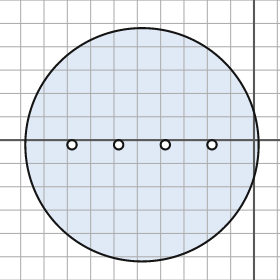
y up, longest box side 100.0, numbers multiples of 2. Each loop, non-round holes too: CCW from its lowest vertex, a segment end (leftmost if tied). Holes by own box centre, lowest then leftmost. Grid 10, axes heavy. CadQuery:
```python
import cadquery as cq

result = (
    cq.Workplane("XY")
    .moveTo(-48.0, -2.0)
    .circle(50.0)
    .moveTo(-78.0, -2.0)
    .circle(2.0)
    .moveTo(-58.0, -2.0)
    .circle(2.0)
    .moveTo(-38.0, -2.0)
    .circle(2.0)
    .moveTo(-18.0, -2.0)
    .circle(2.0)
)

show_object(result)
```